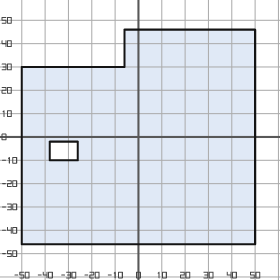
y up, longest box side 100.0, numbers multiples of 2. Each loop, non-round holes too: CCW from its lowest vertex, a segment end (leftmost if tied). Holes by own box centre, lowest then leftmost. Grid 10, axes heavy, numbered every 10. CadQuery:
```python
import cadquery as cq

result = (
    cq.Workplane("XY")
    .moveTo(-50.0, -46.0)
    .lineTo(50.0, -46.0)
    .lineTo(50.0, 46.0)
    .lineTo(-6.0, 46.0)
    .lineTo(-6.0, 30.0)
    .lineTo(-50.0, 30.0)
    .close()
    .moveTo(-38.0, -10.0)
    .lineTo(-26.0, -10.0)
    .lineTo(-26.0, -2.0)
    .lineTo(-38.0, -2.0)
    .close()
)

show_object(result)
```